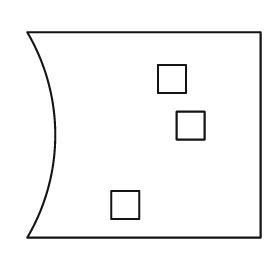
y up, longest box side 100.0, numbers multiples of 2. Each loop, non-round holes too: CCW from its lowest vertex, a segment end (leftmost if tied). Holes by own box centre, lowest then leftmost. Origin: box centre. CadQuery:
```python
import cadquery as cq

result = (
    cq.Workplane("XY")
    .moveTo(-50.0, -44.0)
    .lineTo(50.0, -44.0)
    .lineTo(50.0, 44.0)
    .lineTo(-50.0, 44.0)
    .threePointArc((-38.0, 0.0), (-50.0, -44.0))
    .close()
    .moveTo(-14.0, -36.0)
    .lineTo(-2.0, -36.0)
    .lineTo(-2.0, -24.0)
    .lineTo(-14.0, -24.0)
    .close()
    .moveTo(14.0, -2.0)
    .lineTo(26.0, -2.0)
    .lineTo(26.0, 10.0)
    .lineTo(14.0, 10.0)
    .close()
    .moveTo(6.0, 18.0)
    .lineTo(18.0, 18.0)
    .lineTo(18.0, 30.0)
    .lineTo(6.0, 30.0)
    .close()
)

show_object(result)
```